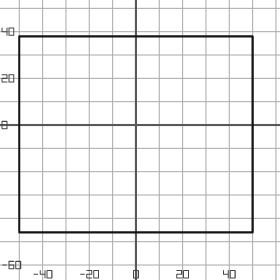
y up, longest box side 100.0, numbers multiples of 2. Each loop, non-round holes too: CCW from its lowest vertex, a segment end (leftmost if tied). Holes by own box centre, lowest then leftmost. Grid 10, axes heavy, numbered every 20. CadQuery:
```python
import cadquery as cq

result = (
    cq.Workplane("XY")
    .moveTo(-50.0, -46.0)
    .lineTo(50.0, -46.0)
    .lineTo(50.0, 38.0)
    .lineTo(-50.0, 38.0)
    .close()
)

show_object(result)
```